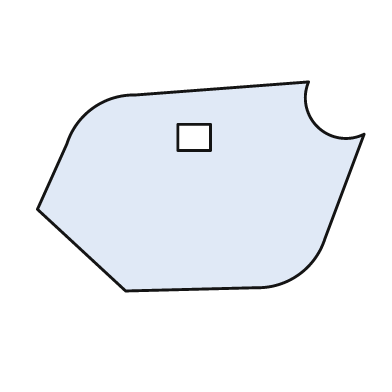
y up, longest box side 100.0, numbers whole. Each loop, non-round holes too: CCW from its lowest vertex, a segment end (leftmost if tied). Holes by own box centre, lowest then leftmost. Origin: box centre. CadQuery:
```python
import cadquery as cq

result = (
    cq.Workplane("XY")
    .moveTo(-23.0, -32.0)
    .lineTo(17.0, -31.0)
    .threePointArc((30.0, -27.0), (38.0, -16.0))
    .lineTo(50.0, 16.0)
    .threePointArc((36.0, 18.0), (33.0, 32.0))
    .lineTo(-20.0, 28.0)
    .threePointArc((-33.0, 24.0), (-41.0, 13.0))
    .lineTo(-50.0, -7.0)
    .close()
    .moveTo(-7.0, 11.0)
    .lineTo(3.0, 11.0)
    .lineTo(3.0, 19.0)
    .lineTo(-7.0, 19.0)
    .close()
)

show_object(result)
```